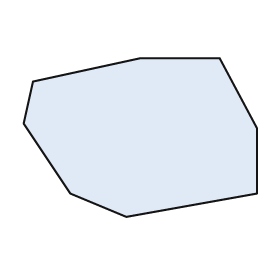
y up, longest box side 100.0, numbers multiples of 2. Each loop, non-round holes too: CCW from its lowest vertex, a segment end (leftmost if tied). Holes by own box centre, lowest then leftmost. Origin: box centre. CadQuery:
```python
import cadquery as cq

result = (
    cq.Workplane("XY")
    .moveTo(-6.0, -34.0)
    .lineTo(50.0, -24.0)
    .lineTo(50.0, 4.0)
    .lineTo(34.0, 34.0)
    .lineTo(0.0, 34.0)
    .lineTo(-46.0, 24.0)
    .lineTo(-50.0, 6.0)
    .lineTo(-30.0, -24.0)
    .close()
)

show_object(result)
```